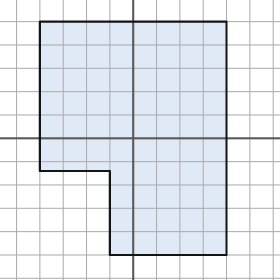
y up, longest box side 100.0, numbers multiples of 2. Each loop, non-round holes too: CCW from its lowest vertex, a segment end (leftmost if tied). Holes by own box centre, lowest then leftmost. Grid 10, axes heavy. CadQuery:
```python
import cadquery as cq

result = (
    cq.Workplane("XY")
    .moveTo(-10.0, -50.0)
    .lineTo(40.0, -50.0)
    .lineTo(40.0, 50.0)
    .lineTo(-40.0, 50.0)
    .lineTo(-40.0, -14.0)
    .lineTo(-10.0, -14.0)
    .close()
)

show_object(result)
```